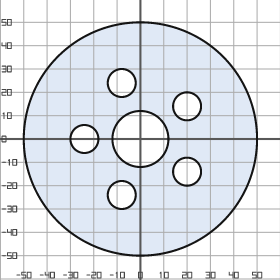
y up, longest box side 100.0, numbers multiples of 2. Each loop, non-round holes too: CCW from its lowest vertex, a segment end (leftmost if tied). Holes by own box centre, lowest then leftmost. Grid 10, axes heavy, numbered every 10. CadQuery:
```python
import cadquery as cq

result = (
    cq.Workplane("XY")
    .moveTo(0.0, 0.0)
    .circle(50.0)
    .moveTo(-8.0, -24.0)
    .circle(6.0)
    .moveTo(20.0, -14.0)
    .circle(6.0)
    .moveTo(-24.0, 0.0)
    .circle(6.0)
    .moveTo(0.0, 0.0)
    .circle(12.0)
    .moveTo(20.0, 14.0)
    .circle(6.0)
    .moveTo(-8.0, 24.0)
    .circle(6.0)
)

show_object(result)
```